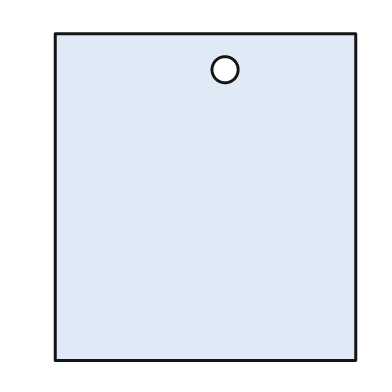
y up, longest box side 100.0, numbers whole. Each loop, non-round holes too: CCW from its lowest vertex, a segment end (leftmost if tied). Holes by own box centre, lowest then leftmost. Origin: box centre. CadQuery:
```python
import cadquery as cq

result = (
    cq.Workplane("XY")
    .moveTo(-46.0, -50.0)
    .lineTo(46.0, -50.0)
    .lineTo(46.0, 50.0)
    .lineTo(-46.0, 50.0)
    .close()
    .moveTo(6.0, 39.0)
    .circle(4.0)
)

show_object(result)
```